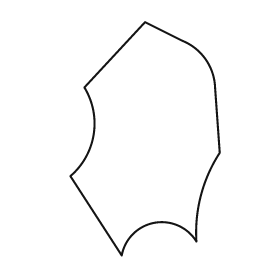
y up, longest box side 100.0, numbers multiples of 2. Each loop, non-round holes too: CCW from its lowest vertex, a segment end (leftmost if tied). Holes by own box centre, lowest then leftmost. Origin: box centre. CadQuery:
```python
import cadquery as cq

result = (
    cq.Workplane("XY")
    .moveTo(-10.0, -50.0)
    .threePointArc((4.0, -36.0), (22.0, -44.0))
    .threePointArc((24.0, -24.0), (32.0, -6.0))
    .lineTo(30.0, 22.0)
    .threePointArc((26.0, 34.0), (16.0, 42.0))
    .lineTo(0.0, 50.0)
    .lineTo(-26.0, 22.0)
    .threePointArc((-22.0, 2.0), (-32.0, -16.0))
    .close()
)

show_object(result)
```